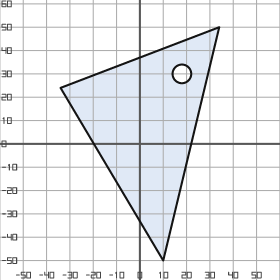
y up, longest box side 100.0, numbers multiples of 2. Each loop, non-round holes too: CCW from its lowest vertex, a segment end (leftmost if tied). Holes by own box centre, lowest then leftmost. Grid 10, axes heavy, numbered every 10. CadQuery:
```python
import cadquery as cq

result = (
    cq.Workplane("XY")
    .moveTo(10.0, -50.0)
    .lineTo(34.0, 50.0)
    .lineTo(-34.0, 24.0)
    .close()
    .moveTo(18.0, 30.0)
    .circle(4.0)
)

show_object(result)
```